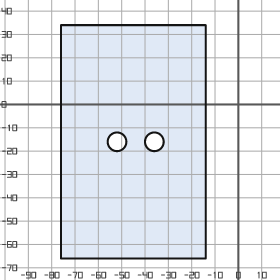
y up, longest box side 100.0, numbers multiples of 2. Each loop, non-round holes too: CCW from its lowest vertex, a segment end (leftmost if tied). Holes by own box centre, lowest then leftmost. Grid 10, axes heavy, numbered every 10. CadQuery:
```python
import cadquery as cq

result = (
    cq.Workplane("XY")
    .moveTo(-76.0, -66.0)
    .lineTo(-14.0, -66.0)
    .lineTo(-14.0, 34.0)
    .lineTo(-76.0, 34.0)
    .close()
    .moveTo(-52.0, -16.0)
    .circle(4.0)
    .moveTo(-36.0, -16.0)
    .circle(4.0)
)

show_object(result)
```